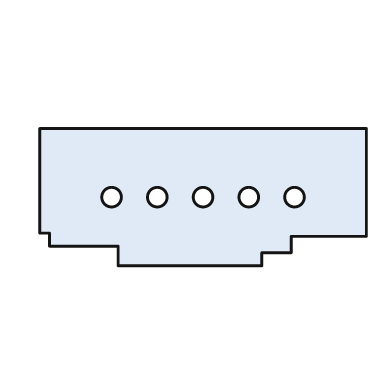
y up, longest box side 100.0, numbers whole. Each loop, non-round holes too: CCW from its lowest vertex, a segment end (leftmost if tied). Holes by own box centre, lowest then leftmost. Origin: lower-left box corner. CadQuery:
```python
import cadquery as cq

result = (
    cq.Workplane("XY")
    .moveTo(24.0, 0.0)
    .lineTo(68.0, 0.0)
    .lineTo(68.0, 4.0)
    .lineTo(77.0, 4.0)
    .lineTo(77.0, 9.0)
    .lineTo(100.0, 9.0)
    .lineTo(100.0, 42.0)
    .lineTo(0.0, 42.0)
    .lineTo(0.0, 10.0)
    .lineTo(3.0, 10.0)
    .lineTo(3.0, 6.0)
    .lineTo(24.0, 6.0)
    .close()
    .moveTo(22.0, 21.0)
    .circle(3.0)
    .moveTo(36.0, 21.0)
    .circle(3.0)
    .moveTo(50.0, 21.0)
    .circle(3.0)
    .moveTo(64.0, 21.0)
    .circle(3.0)
    .moveTo(78.0, 21.0)
    .circle(3.0)
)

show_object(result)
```